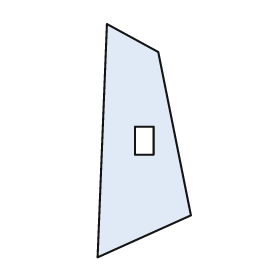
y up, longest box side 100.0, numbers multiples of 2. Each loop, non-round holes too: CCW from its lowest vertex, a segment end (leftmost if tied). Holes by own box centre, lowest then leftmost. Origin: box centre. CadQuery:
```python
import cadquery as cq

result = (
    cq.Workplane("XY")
    .moveTo(-20.0, -50.0)
    .lineTo(20.0, -32.0)
    .lineTo(6.0, 38.0)
    .lineTo(-16.0, 50.0)
    .close()
    .moveTo(-4.0, -6.0)
    .lineTo(4.0, -6.0)
    .lineTo(4.0, 6.0)
    .lineTo(-4.0, 6.0)
    .close()
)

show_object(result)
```